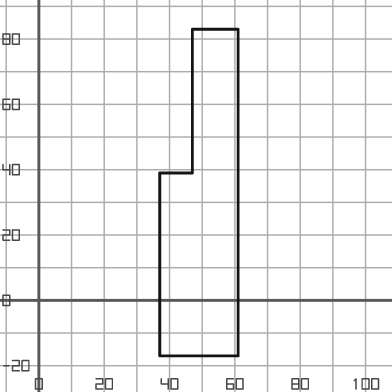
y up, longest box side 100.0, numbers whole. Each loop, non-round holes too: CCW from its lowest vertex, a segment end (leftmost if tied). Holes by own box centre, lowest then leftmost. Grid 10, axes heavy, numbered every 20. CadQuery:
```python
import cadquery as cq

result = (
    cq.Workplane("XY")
    .moveTo(37.0, -17.0)
    .lineTo(61.0, -17.0)
    .lineTo(61.0, 83.0)
    .lineTo(47.0, 83.0)
    .lineTo(47.0, 39.0)
    .lineTo(37.0, 39.0)
    .close()
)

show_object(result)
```